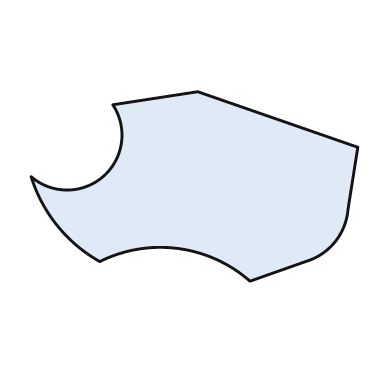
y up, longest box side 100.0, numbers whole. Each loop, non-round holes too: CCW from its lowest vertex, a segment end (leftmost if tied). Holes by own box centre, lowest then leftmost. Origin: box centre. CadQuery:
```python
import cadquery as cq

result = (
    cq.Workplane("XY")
    .moveTo(17.0, -29.0)
    .lineTo(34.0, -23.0)
    .threePointArc((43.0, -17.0), (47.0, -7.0))
    .lineTo(50.0, 12.0)
    .lineTo(1.0, 29.0)
    .lineTo(-25.0, 25.0)
    .threePointArc((-28.0, 3.0), (-50.0, 3.0))
    .threePointArc((-42.0, -12.0), (-29.0, -23.0))
    .threePointArc((-5.0, -19.0), (17.0, -29.0))
    .close()
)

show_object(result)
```